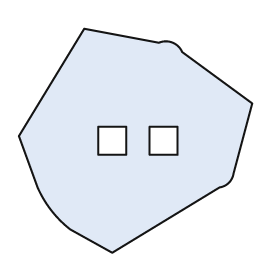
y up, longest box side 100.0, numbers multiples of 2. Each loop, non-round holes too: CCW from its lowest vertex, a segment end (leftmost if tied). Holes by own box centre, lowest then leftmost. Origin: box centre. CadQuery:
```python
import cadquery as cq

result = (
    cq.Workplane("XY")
    .moveTo(-10.0, -48.0)
    .lineTo(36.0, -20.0)
    .threePointArc((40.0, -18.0), (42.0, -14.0))
    .lineTo(50.0, 16.0)
    .lineTo(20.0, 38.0)
    .threePointArc((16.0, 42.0), (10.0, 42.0))
    .lineTo(-22.0, 48.0)
    .lineTo(-50.0, 2.0)
    .lineTo(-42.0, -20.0)
    .threePointArc((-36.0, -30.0), (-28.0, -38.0))
    .close()
    .moveTo(-16.0, -6.0)
    .lineTo(-4.0, -6.0)
    .lineTo(-4.0, 6.0)
    .lineTo(-16.0, 6.0)
    .close()
    .moveTo(6.0, -6.0)
    .lineTo(18.0, -6.0)
    .lineTo(18.0, 6.0)
    .lineTo(6.0, 6.0)
    .close()
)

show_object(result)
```